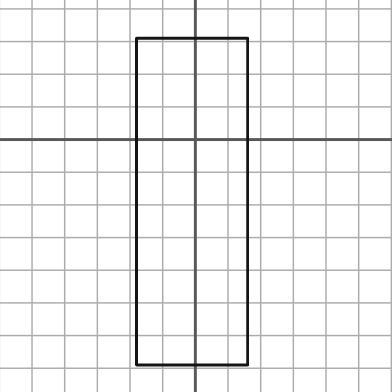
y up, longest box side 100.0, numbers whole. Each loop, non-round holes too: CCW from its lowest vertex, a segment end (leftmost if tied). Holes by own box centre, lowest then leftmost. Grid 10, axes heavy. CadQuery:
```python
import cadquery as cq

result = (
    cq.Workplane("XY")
    .moveTo(-18.0, -69.0)
    .lineTo(16.0, -69.0)
    .lineTo(16.0, 31.0)
    .lineTo(-18.0, 31.0)
    .close()
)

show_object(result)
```